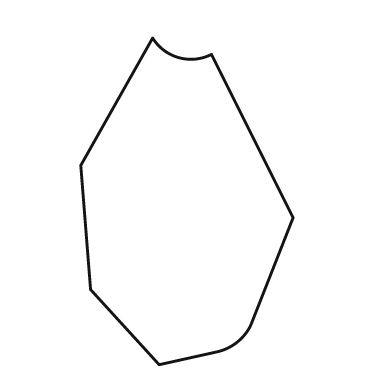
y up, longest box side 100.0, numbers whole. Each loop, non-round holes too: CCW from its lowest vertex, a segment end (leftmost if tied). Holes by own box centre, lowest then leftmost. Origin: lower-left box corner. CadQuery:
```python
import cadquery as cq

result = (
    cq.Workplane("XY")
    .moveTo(24.0, 0.0)
    .lineTo(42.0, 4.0)
    .threePointArc((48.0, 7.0), (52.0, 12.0))
    .lineTo(65.0, 45.0)
    .lineTo(40.0, 95.0)
    .threePointArc((30.0, 94.0), (22.0, 100.0))
    .lineTo(0.0, 61.0)
    .lineTo(3.0, 23.0)
    .close()
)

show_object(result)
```